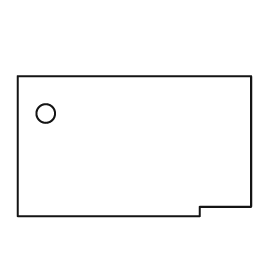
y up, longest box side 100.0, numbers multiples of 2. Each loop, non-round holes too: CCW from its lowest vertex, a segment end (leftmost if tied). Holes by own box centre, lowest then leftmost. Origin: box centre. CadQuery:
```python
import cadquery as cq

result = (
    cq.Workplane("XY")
    .moveTo(-50.0, -30.0)
    .lineTo(28.0, -30.0)
    .lineTo(28.0, -26.0)
    .lineTo(50.0, -26.0)
    .lineTo(50.0, 30.0)
    .lineTo(-50.0, 30.0)
    .close()
    .moveTo(-38.0, 14.0)
    .circle(4.0)
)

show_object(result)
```